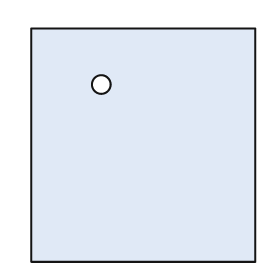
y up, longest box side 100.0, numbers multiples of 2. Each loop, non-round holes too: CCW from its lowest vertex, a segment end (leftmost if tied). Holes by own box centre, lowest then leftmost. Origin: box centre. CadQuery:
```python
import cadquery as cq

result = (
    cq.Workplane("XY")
    .moveTo(-48.0, -50.0)
    .lineTo(48.0, -50.0)
    .lineTo(48.0, 50.0)
    .lineTo(-48.0, 50.0)
    .close()
    .moveTo(-18.0, 26.0)
    .circle(4.0)
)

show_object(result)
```